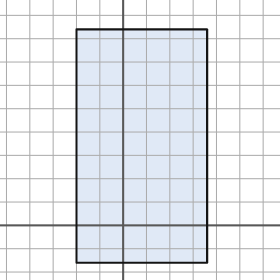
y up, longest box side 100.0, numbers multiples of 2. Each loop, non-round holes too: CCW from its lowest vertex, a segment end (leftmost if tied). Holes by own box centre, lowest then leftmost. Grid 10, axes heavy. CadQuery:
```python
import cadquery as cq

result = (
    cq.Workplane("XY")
    .moveTo(-20.0, -16.0)
    .lineTo(36.0, -16.0)
    .lineTo(36.0, 84.0)
    .lineTo(-20.0, 84.0)
    .close()
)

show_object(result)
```